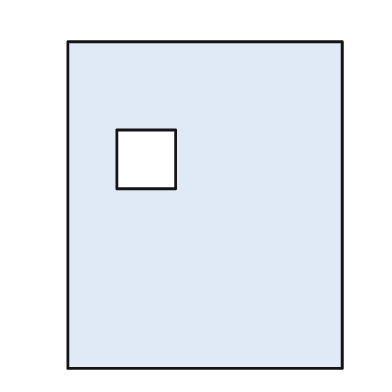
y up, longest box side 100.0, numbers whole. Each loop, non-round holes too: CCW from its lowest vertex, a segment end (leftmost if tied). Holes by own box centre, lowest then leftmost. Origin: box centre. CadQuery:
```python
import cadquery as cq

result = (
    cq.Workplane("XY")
    .moveTo(-42.0, -50.0)
    .lineTo(42.0, -50.0)
    .lineTo(42.0, 50.0)
    .lineTo(-42.0, 50.0)
    .close()
    .moveTo(-27.0, 5.0)
    .lineTo(-9.0, 5.0)
    .lineTo(-9.0, 23.0)
    .lineTo(-27.0, 23.0)
    .close()
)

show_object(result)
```